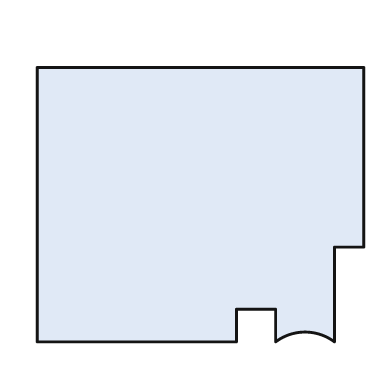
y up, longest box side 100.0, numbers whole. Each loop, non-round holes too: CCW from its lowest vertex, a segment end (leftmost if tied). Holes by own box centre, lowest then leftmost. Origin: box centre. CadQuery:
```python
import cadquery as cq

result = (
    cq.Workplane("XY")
    .moveTo(-50.0, -42.0)
    .lineTo(11.0, -42.0)
    .lineTo(11.0, -32.0)
    .lineTo(23.0, -32.0)
    .lineTo(23.0, -42.0)
    .threePointArc((32.0, -39.0), (41.0, -42.0))
    .lineTo(41.0, -13.0)
    .lineTo(50.0, -13.0)
    .lineTo(50.0, 42.0)
    .lineTo(-50.0, 42.0)
    .close()
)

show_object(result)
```